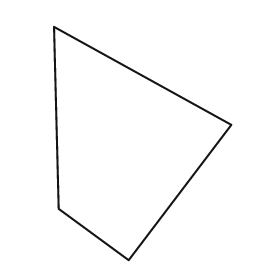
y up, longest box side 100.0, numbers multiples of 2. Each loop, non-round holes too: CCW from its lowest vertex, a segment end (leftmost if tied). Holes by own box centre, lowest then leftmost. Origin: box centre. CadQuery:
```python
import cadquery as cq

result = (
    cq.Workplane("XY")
    .moveTo(-6.0, -50.0)
    .lineTo(38.0, 8.0)
    .lineTo(-38.0, 50.0)
    .lineTo(-36.0, -28.0)
    .close()
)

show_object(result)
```